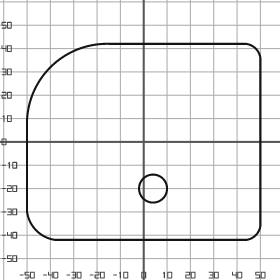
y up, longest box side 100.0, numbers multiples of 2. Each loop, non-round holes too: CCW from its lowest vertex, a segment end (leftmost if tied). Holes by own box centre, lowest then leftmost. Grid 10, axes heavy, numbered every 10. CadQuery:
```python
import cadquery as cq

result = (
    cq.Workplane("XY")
    .moveTo(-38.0, -42.0)
    .lineTo(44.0, -42.0)
    .threePointArc((48.0, -40.0), (50.0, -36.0))
    .lineTo(50.0, 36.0)
    .threePointArc((48.0, 40.0), (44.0, 42.0))
    .lineTo(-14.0, 42.0)
    .threePointArc((-40.0, 32.0), (-50.0, 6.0))
    .lineTo(-50.0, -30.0)
    .threePointArc((-46.0, -38.0), (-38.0, -42.0))
    .close()
    .moveTo(4.0, -20.0)
    .circle(6.0)
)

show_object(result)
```